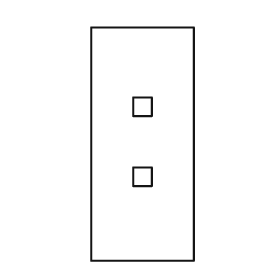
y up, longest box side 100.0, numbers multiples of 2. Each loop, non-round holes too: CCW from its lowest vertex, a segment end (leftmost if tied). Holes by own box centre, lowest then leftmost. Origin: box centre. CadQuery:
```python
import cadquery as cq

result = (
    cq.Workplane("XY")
    .moveTo(-22.0, -50.0)
    .lineTo(22.0, -50.0)
    .lineTo(22.0, 50.0)
    .lineTo(-22.0, 50.0)
    .close()
    .moveTo(-4.0, -18.0)
    .lineTo(4.0, -18.0)
    .lineTo(4.0, -10.0)
    .lineTo(-4.0, -10.0)
    .close()
    .moveTo(-4.0, 12.0)
    .lineTo(4.0, 12.0)
    .lineTo(4.0, 20.0)
    .lineTo(-4.0, 20.0)
    .close()
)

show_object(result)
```